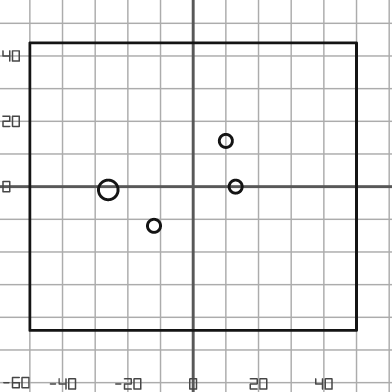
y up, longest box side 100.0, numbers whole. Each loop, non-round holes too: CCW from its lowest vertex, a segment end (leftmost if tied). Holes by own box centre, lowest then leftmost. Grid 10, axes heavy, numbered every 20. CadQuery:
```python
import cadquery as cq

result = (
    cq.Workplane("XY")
    .moveTo(-50.0, -44.0)
    .lineTo(50.0, -44.0)
    .lineTo(50.0, 44.0)
    .lineTo(-50.0, 44.0)
    .close()
    .moveTo(-12.0, -12.0)
    .circle(2.0)
    .moveTo(-26.0, -1.0)
    .circle(3.0)
    .moveTo(13.0, 0.0)
    .circle(2.0)
    .moveTo(10.0, 14.0)
    .circle(2.0)
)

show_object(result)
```